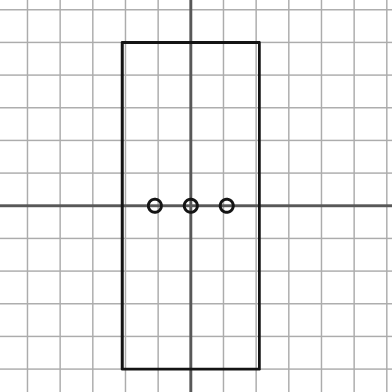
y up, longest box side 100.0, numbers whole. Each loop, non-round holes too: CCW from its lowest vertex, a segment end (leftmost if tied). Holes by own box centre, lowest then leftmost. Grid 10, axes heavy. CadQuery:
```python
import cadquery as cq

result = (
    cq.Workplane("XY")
    .moveTo(-21.0, -50.0)
    .lineTo(21.0, -50.0)
    .lineTo(21.0, 50.0)
    .lineTo(-21.0, 50.0)
    .close()
    .moveTo(-11.0, 0.0)
    .circle(2.0)
    .moveTo(0.0, 0.0)
    .circle(2.0)
    .moveTo(11.0, 0.0)
    .circle(2.0)
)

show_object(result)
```